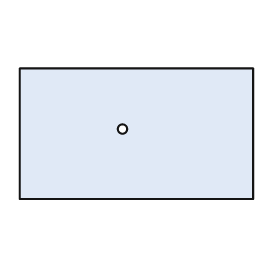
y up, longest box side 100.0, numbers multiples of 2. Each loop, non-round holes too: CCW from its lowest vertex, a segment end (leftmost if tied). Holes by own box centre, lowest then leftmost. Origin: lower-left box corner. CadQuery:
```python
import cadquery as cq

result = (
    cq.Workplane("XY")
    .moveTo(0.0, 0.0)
    .lineTo(100.0, 0.0)
    .lineTo(100.0, 56.0)
    .lineTo(0.0, 56.0)
    .close()
    .moveTo(44.0, 30.0)
    .circle(2.0)
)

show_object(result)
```